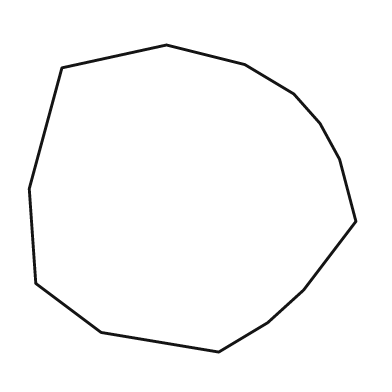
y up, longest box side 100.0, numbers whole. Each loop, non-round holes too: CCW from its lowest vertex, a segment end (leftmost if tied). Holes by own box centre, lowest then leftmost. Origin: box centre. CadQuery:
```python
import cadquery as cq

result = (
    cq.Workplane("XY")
    .moveTo(8.0, -47.0)
    .lineTo(23.0, -38.0)
    .lineTo(34.0, -28.0)
    .lineTo(50.0, -7.0)
    .lineTo(45.0, 12.0)
    .lineTo(39.0, 23.0)
    .lineTo(31.0, 32.0)
    .lineTo(16.0, 41.0)
    .lineTo(-8.0, 47.0)
    .lineTo(-40.0, 40.0)
    .lineTo(-50.0, 3.0)
    .lineTo(-48.0, -26.0)
    .lineTo(-28.0, -41.0)
    .close()
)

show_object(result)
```